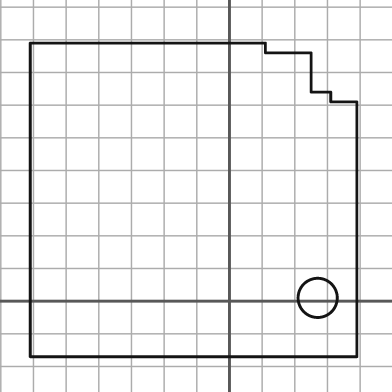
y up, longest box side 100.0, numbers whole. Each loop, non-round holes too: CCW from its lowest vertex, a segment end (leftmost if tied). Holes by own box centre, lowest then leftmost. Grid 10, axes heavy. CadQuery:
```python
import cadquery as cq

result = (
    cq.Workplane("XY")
    .moveTo(-61.0, -17.0)
    .lineTo(39.0, -17.0)
    .lineTo(39.0, 61.0)
    .lineTo(31.0, 61.0)
    .lineTo(31.0, 64.0)
    .lineTo(25.0, 64.0)
    .lineTo(25.0, 76.0)
    .lineTo(11.0, 76.0)
    .lineTo(11.0, 79.0)
    .lineTo(-61.0, 79.0)
    .close()
    .moveTo(27.0, 1.0)
    .circle(6.0)
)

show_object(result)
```